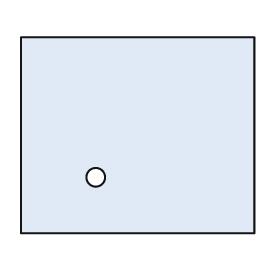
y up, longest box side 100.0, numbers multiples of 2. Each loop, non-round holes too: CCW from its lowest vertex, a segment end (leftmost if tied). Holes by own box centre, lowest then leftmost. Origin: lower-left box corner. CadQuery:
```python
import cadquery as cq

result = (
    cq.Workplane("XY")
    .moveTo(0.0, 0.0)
    .lineTo(100.0, 0.0)
    .lineTo(100.0, 84.0)
    .lineTo(0.0, 84.0)
    .close()
    .moveTo(32.0, 24.0)
    .circle(4.0)
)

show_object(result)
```